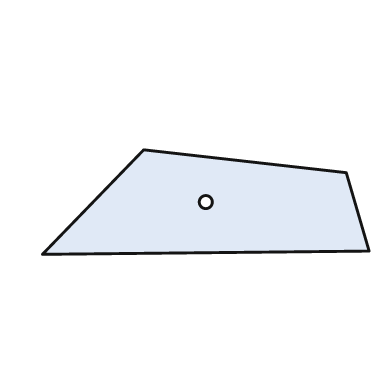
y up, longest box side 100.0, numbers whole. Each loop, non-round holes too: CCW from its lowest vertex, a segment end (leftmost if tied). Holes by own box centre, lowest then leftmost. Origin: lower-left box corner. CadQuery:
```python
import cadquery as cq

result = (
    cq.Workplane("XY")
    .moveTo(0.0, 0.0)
    .lineTo(100.0, 1.0)
    .lineTo(93.0, 25.0)
    .lineTo(31.0, 32.0)
    .close()
    .moveTo(50.0, 16.0)
    .circle(2.0)
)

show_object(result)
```